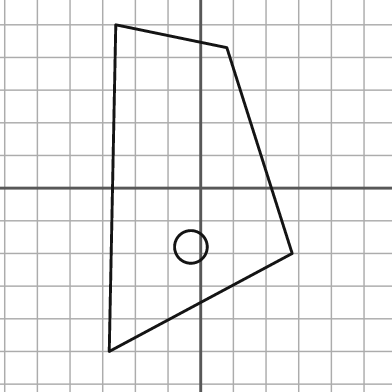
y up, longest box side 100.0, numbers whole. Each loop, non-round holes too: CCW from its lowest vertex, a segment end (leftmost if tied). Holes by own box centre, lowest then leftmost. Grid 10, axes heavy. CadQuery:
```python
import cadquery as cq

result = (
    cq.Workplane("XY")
    .moveTo(-28.0, -50.0)
    .lineTo(28.0, -20.0)
    .lineTo(8.0, 43.0)
    .lineTo(-26.0, 50.0)
    .close()
    .moveTo(-3.0, -18.0)
    .circle(5.0)
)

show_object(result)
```